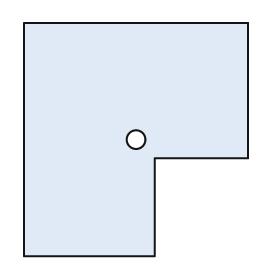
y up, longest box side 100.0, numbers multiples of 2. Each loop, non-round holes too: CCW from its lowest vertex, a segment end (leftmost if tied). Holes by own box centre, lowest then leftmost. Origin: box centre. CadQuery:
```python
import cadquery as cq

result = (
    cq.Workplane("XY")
    .moveTo(-48.0, -50.0)
    .lineTo(8.0, -50.0)
    .lineTo(8.0, -8.0)
    .lineTo(48.0, -8.0)
    .lineTo(48.0, 50.0)
    .lineTo(-48.0, 50.0)
    .close()
    .moveTo(0.0, 0.0)
    .circle(4.0)
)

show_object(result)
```